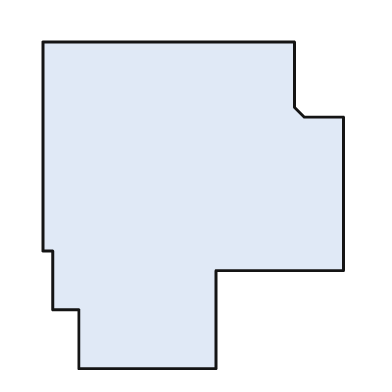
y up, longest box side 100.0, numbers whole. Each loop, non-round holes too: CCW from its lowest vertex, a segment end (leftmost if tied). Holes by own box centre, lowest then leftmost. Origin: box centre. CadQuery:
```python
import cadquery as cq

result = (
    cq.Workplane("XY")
    .moveTo(-35.0, -50.0)
    .lineTo(7.0, -50.0)
    .lineTo(7.0, -20.0)
    .lineTo(46.0, -20.0)
    .lineTo(46.0, 27.0)
    .lineTo(34.0, 27.0)
    .lineTo(31.0, 30.0)
    .lineTo(31.0, 50.0)
    .lineTo(-46.0, 50.0)
    .lineTo(-46.0, -14.0)
    .lineTo(-43.0, -14.0)
    .lineTo(-43.0, -32.0)
    .lineTo(-35.0, -32.0)
    .close()
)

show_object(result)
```